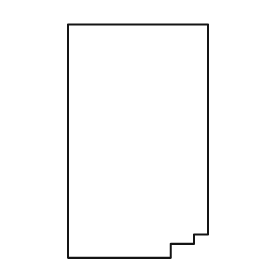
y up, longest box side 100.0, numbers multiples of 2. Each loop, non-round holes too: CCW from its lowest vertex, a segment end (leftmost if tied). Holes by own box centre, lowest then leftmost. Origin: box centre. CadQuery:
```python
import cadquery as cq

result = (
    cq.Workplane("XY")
    .moveTo(-30.0, -50.0)
    .lineTo(14.0, -50.0)
    .lineTo(14.0, -44.0)
    .lineTo(24.0, -44.0)
    .lineTo(24.0, -40.0)
    .lineTo(30.0, -40.0)
    .lineTo(30.0, 50.0)
    .lineTo(-30.0, 50.0)
    .close()
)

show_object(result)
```